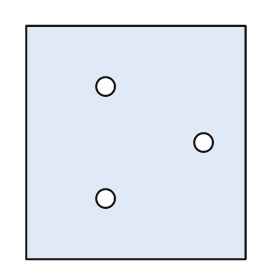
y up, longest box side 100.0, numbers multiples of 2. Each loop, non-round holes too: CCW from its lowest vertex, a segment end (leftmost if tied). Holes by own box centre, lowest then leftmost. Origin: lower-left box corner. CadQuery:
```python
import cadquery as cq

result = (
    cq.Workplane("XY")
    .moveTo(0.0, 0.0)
    .lineTo(94.0, 0.0)
    .lineTo(94.0, 100.0)
    .lineTo(0.0, 100.0)
    .close()
    .moveTo(34.0, 26.0)
    .circle(4.0)
    .moveTo(76.0, 50.0)
    .circle(4.0)
    .moveTo(34.0, 74.0)
    .circle(4.0)
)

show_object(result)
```